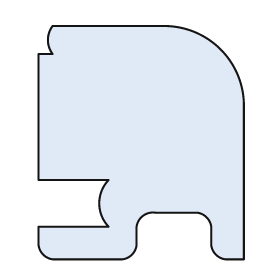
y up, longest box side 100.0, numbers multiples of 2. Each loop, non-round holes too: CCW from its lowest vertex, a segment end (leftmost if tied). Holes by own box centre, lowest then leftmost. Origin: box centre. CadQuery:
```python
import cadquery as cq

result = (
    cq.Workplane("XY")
    .moveTo(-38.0, -50.0)
    .lineTo(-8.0, -50.0)
    .threePointArc((-4.0, -48.0), (-2.0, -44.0))
    .lineTo(-2.0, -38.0)
    .threePointArc((0.0, -32.0), (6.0, -30.0))
    .lineTo(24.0, -30.0)
    .threePointArc((28.0, -32.0), (30.0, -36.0))
    .lineTo(30.0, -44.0)
    .threePointArc((32.0, -48.0), (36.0, -50.0))
    .lineTo(44.0, -50.0)
    .lineTo(44.0, 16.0)
    .threePointArc((34.0, 40.0), (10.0, 50.0))
    .lineTo(-38.0, 50.0)
    .threePointArc((-40.0, 44.0), (-38.0, 38.0))
    .lineTo(-44.0, 38.0)
    .lineTo(-44.0, -16.0)
    .lineTo(-14.0, -16.0)
    .threePointArc((-18.0, -26.0), (-14.0, -36.0))
    .lineTo(-44.0, -36.0)
    .lineTo(-44.0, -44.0)
    .threePointArc((-42.0, -48.0), (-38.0, -50.0))
    .close()
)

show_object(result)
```